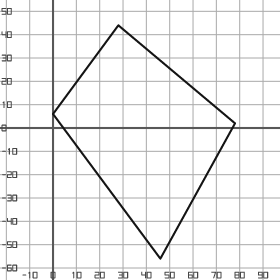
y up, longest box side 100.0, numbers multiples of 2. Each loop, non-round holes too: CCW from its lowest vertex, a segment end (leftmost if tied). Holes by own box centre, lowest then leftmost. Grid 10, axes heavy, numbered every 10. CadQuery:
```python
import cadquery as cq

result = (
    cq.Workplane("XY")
    .moveTo(46.0, -56.0)
    .lineTo(78.0, 2.0)
    .lineTo(28.0, 44.0)
    .lineTo(0.0, 6.0)
    .close()
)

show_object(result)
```